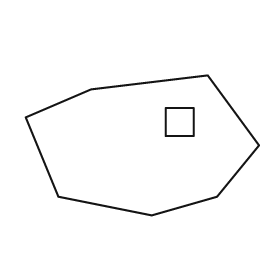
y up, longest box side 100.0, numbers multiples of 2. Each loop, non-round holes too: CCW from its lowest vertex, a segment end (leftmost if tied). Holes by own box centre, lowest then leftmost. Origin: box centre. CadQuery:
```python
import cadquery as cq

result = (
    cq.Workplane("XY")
    .moveTo(4.0, -30.0)
    .lineTo(32.0, -22.0)
    .lineTo(50.0, 0.0)
    .lineTo(28.0, 30.0)
    .lineTo(-22.0, 24.0)
    .lineTo(-50.0, 12.0)
    .lineTo(-36.0, -22.0)
    .close()
    .moveTo(10.0, 4.0)
    .lineTo(22.0, 4.0)
    .lineTo(22.0, 16.0)
    .lineTo(10.0, 16.0)
    .close()
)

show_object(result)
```